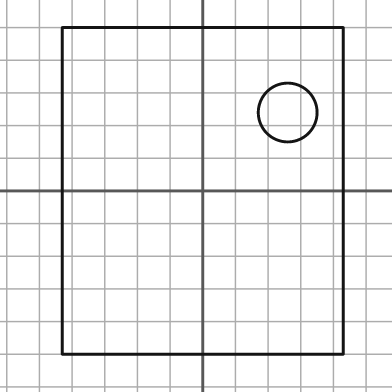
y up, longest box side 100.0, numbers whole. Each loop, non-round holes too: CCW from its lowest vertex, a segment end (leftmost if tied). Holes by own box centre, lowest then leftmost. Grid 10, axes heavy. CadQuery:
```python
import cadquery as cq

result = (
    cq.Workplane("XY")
    .moveTo(-43.0, -50.0)
    .lineTo(43.0, -50.0)
    .lineTo(43.0, 50.0)
    .lineTo(-43.0, 50.0)
    .close()
    .moveTo(26.0, 24.0)
    .circle(9.0)
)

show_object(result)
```